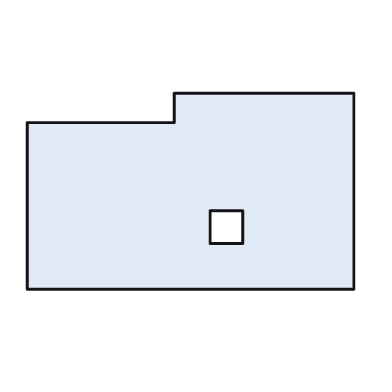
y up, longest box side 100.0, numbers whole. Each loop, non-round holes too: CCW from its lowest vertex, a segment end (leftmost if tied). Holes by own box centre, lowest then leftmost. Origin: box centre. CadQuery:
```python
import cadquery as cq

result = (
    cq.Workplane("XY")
    .moveTo(-50.0, -30.0)
    .lineTo(50.0, -30.0)
    .lineTo(50.0, 30.0)
    .lineTo(-5.0, 30.0)
    .lineTo(-5.0, 21.0)
    .lineTo(-50.0, 21.0)
    .close()
    .moveTo(6.0, -16.0)
    .lineTo(16.0, -16.0)
    .lineTo(16.0, -6.0)
    .lineTo(6.0, -6.0)
    .close()
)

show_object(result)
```